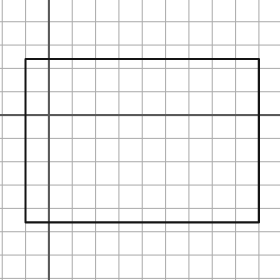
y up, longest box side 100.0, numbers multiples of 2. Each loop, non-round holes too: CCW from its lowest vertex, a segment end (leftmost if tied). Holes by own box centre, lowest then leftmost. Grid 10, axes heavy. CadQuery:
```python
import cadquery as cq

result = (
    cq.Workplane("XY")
    .moveTo(-10.0, -46.0)
    .lineTo(90.0, -46.0)
    .lineTo(90.0, 24.0)
    .lineTo(-10.0, 24.0)
    .close()
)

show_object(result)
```